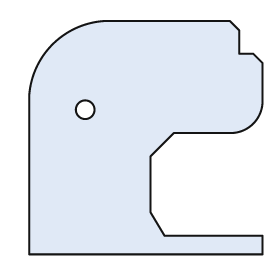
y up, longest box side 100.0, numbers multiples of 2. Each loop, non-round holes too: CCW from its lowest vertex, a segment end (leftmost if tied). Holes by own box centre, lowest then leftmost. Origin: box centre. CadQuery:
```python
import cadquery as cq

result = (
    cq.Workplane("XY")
    .moveTo(-50.0, -50.0)
    .lineTo(50.0, -50.0)
    .lineTo(50.0, -42.0)
    .lineTo(8.0, -42.0)
    .lineTo(2.0, -32.0)
    .lineTo(2.0, -8.0)
    .lineTo(12.0, 2.0)
    .lineTo(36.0, 2.0)
    .threePointArc((46.0, 6.0), (50.0, 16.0))
    .lineTo(50.0, 32.0)
    .lineTo(46.0, 36.0)
    .lineTo(40.0, 36.0)
    .lineTo(40.0, 46.0)
    .lineTo(36.0, 50.0)
    .lineTo(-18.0, 50.0)
    .threePointArc((-40.0, 40.0), (-50.0, 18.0))
    .close()
    .moveTo(-26.0, 12.0)
    .circle(4.0)
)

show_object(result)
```